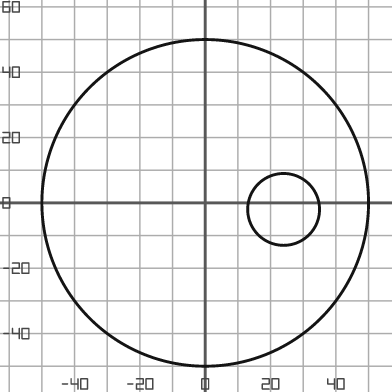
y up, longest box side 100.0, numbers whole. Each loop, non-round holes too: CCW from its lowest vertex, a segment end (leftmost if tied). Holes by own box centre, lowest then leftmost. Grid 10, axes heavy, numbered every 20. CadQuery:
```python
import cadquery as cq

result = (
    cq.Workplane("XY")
    .moveTo(0.0, 0.0)
    .circle(50.0)
    .moveTo(24.0, -2.0)
    .circle(11.0)
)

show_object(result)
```